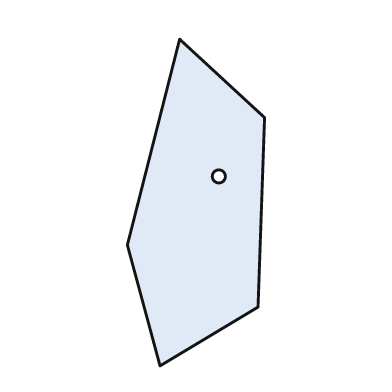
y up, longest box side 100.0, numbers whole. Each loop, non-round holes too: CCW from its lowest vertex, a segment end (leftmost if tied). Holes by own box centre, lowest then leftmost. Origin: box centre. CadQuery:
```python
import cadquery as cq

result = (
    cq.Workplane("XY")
    .moveTo(-11.0, -50.0)
    .lineTo(19.0, -32.0)
    .lineTo(21.0, 26.0)
    .lineTo(-5.0, 50.0)
    .lineTo(-21.0, -13.0)
    .close()
    .moveTo(7.0, 8.0)
    .circle(2.0)
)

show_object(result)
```